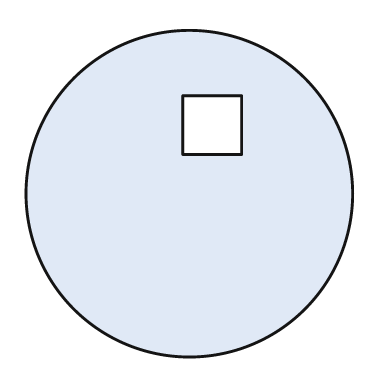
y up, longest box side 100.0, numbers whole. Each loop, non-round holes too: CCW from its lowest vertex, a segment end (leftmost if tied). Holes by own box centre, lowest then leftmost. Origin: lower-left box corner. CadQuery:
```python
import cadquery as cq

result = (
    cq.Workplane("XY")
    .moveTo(50.0, 50.0)
    .circle(50.0)
    .moveTo(48.0, 62.0)
    .lineTo(66.0, 62.0)
    .lineTo(66.0, 80.0)
    .lineTo(48.0, 80.0)
    .close()
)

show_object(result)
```